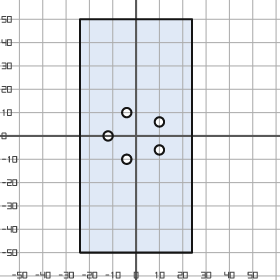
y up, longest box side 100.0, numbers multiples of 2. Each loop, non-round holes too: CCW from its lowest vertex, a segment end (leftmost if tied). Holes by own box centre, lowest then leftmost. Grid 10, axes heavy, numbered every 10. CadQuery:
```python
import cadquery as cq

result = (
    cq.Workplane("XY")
    .moveTo(-24.0, -50.0)
    .lineTo(24.0, -50.0)
    .lineTo(24.0, 50.0)
    .lineTo(-24.0, 50.0)
    .close()
    .moveTo(-4.0, -10.0)
    .circle(2.0)
    .moveTo(10.0, -6.0)
    .circle(2.0)
    .moveTo(-12.0, 0.0)
    .circle(2.0)
    .moveTo(10.0, 6.0)
    .circle(2.0)
    .moveTo(-4.0, 10.0)
    .circle(2.0)
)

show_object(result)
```